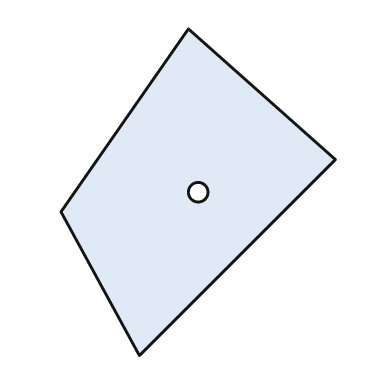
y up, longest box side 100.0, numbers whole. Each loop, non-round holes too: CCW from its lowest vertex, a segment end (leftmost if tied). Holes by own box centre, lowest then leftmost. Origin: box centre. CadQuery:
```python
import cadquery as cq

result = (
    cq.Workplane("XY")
    .moveTo(-18.0, -50.0)
    .lineTo(42.0, 10.0)
    .lineTo(-3.0, 50.0)
    .lineTo(-42.0, -6.0)
    .close()
    .moveTo(0.0, 0.0)
    .circle(3.0)
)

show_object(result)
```